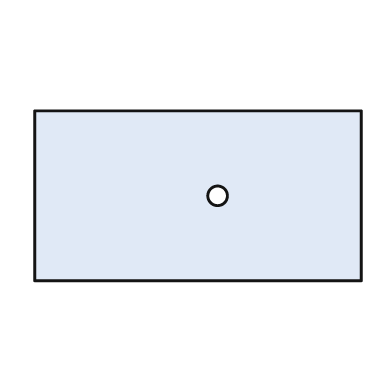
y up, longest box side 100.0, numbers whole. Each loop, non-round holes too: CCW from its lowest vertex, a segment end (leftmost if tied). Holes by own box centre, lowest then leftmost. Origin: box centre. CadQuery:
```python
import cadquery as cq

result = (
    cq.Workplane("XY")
    .moveTo(-50.0, -26.0)
    .lineTo(50.0, -26.0)
    .lineTo(50.0, 26.0)
    .lineTo(-50.0, 26.0)
    .close()
    .moveTo(6.0, 0.0)
    .circle(3.0)
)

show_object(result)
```